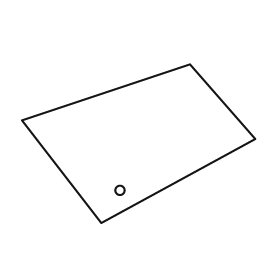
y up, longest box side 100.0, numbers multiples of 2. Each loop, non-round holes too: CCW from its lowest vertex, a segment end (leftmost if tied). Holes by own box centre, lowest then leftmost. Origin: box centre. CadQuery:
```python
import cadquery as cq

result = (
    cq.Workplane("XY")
    .moveTo(-16.0, -34.0)
    .lineTo(50.0, 2.0)
    .lineTo(22.0, 34.0)
    .lineTo(-50.0, 10.0)
    .close()
    .moveTo(-8.0, -20.0)
    .circle(2.0)
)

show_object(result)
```